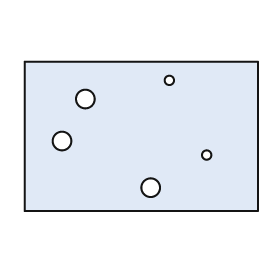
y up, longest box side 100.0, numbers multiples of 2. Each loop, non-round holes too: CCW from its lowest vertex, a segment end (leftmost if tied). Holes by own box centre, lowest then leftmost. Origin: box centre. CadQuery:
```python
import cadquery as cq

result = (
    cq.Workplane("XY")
    .moveTo(-50.0, -32.0)
    .lineTo(50.0, -32.0)
    .lineTo(50.0, 32.0)
    .lineTo(-50.0, 32.0)
    .close()
    .moveTo(4.0, -22.0)
    .circle(4.0)
    .moveTo(28.0, -8.0)
    .circle(2.0)
    .moveTo(-34.0, -2.0)
    .circle(4.0)
    .moveTo(-24.0, 16.0)
    .circle(4.0)
    .moveTo(12.0, 24.0)
    .circle(2.0)
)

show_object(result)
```